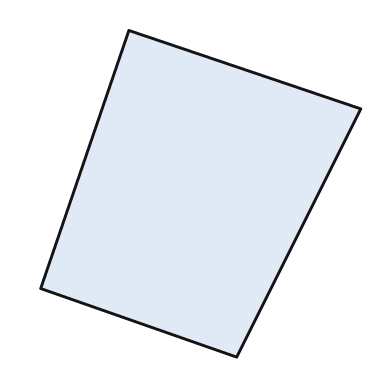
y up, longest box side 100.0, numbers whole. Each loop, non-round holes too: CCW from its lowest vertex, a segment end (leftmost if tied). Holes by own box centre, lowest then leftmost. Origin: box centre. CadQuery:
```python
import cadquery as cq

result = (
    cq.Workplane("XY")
    .moveTo(11.0, -50.0)
    .lineTo(49.0, 26.0)
    .lineTo(-22.0, 50.0)
    .lineTo(-49.0, -29.0)
    .close()
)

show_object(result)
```